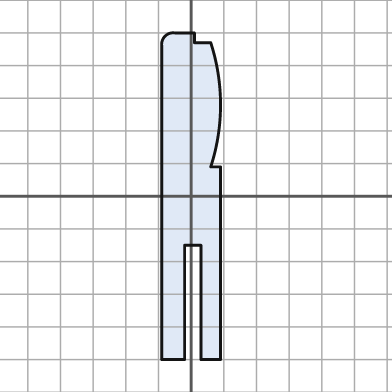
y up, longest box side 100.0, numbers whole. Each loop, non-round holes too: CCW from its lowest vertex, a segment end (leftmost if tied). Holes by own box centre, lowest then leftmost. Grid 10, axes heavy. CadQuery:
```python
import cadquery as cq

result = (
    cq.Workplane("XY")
    .moveTo(-9.0, -50.0)
    .lineTo(-2.0, -50.0)
    .lineTo(-2.0, -15.0)
    .lineTo(3.0, -15.0)
    .lineTo(3.0, -50.0)
    .lineTo(9.0, -50.0)
    .lineTo(9.0, 9.0)
    .lineTo(6.0, 9.0)
    .threePointArc((9.0, 28.0), (6.0, 47.0))
    .lineTo(1.0, 47.0)
    .lineTo(1.0, 50.0)
    .lineTo(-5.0, 50.0)
    .threePointArc((-8.0, 49.0), (-9.0, 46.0))
    .close()
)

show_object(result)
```